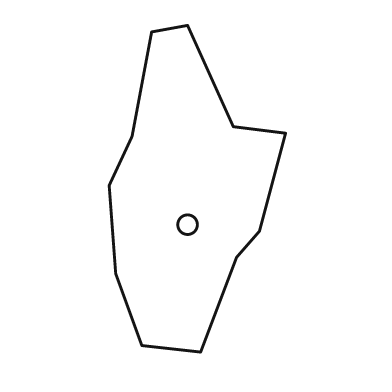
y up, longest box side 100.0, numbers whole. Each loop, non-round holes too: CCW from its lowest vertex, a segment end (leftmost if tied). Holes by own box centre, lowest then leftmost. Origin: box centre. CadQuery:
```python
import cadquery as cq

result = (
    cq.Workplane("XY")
    .moveTo(1.0, -50.0)
    .lineTo(12.0, -21.0)
    .lineTo(19.0, -13.0)
    .lineTo(27.0, 17.0)
    .lineTo(11.0, 19.0)
    .lineTo(-3.0, 50.0)
    .lineTo(-14.0, 48.0)
    .lineTo(-20.0, 16.0)
    .lineTo(-27.0, 1.0)
    .lineTo(-25.0, -26.0)
    .lineTo(-17.0, -48.0)
    .close()
    .moveTo(-3.0, -11.0)
    .circle(3.0)
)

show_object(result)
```